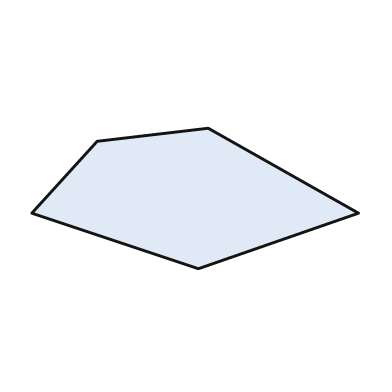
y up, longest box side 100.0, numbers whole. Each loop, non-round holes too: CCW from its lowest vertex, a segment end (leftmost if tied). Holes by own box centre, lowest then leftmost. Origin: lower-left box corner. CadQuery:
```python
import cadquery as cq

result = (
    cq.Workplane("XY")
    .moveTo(51.0, 0.0)
    .lineTo(100.0, 17.0)
    .lineTo(54.0, 43.0)
    .lineTo(20.0, 39.0)
    .lineTo(0.0, 17.0)
    .close()
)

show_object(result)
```